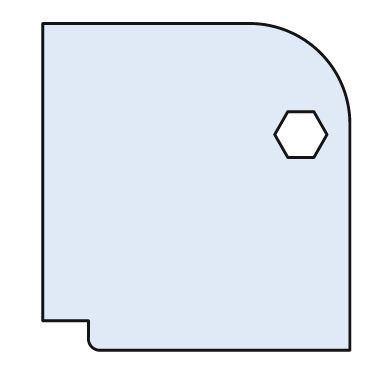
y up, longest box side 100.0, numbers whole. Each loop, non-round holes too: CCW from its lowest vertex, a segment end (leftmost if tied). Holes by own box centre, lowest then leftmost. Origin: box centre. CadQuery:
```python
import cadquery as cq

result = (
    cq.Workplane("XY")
    .moveTo(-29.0, -50.0)
    .lineTo(47.0, -50.0)
    .lineTo(47.0, 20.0)
    .threePointArc((38.0, 41.0), (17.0, 50.0))
    .lineTo(-47.0, 50.0)
    .lineTo(-47.0, -41.0)
    .lineTo(-33.0, -41.0)
    .lineTo(-33.0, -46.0)
    .threePointArc((-32.0, -49.0), (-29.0, -50.0))
    .close()
    .moveTo(28.0, 9.0)
    .lineTo(36.0, 9.0)
    .lineTo(40.0, 16.0)
    .lineTo(36.0, 23.0)
    .lineTo(28.0, 23.0)
    .lineTo(24.0, 16.0)
    .close()
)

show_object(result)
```